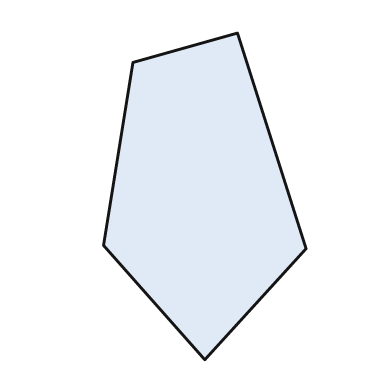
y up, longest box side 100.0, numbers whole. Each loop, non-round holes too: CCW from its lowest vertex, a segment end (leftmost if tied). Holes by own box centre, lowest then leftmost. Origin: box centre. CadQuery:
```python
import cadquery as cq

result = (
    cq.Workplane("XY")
    .moveTo(0.0, -50.0)
    .lineTo(31.0, -16.0)
    .lineTo(10.0, 50.0)
    .lineTo(-22.0, 41.0)
    .lineTo(-31.0, -15.0)
    .close()
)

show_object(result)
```